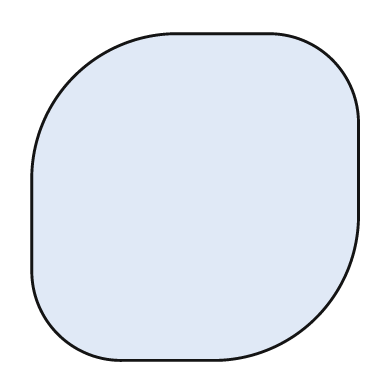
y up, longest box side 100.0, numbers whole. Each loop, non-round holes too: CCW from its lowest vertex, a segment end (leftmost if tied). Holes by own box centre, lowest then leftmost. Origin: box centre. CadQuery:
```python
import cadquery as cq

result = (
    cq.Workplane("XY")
    .moveTo(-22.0, -50.0)
    .lineTo(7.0, -50.0)
    .threePointArc((37.0, -37.0), (50.0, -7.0))
    .lineTo(50.0, 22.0)
    .threePointArc((42.0, 42.0), (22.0, 50.0))
    .lineTo(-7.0, 50.0)
    .threePointArc((-37.0, 37.0), (-50.0, 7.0))
    .lineTo(-50.0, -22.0)
    .threePointArc((-42.0, -42.0), (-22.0, -50.0))
    .close()
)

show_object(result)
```